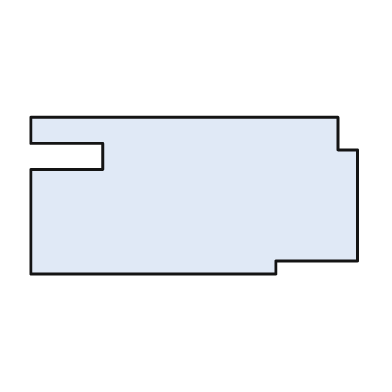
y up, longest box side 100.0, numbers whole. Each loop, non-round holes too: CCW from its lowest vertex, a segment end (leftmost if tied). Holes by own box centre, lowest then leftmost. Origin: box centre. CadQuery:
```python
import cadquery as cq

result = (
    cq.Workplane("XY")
    .moveTo(-50.0, -24.0)
    .lineTo(25.0, -24.0)
    .lineTo(25.0, -20.0)
    .lineTo(50.0, -20.0)
    .lineTo(50.0, 14.0)
    .lineTo(44.0, 14.0)
    .lineTo(44.0, 24.0)
    .lineTo(-50.0, 24.0)
    .lineTo(-50.0, 16.0)
    .lineTo(-28.0, 16.0)
    .lineTo(-28.0, 8.0)
    .lineTo(-50.0, 8.0)
    .close()
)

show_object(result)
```